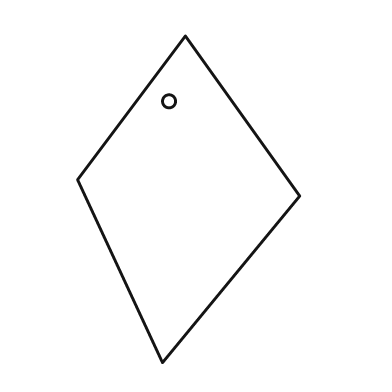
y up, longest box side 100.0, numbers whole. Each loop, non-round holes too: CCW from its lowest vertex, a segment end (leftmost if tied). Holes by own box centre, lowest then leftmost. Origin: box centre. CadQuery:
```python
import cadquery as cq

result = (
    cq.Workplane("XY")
    .moveTo(-8.0, -50.0)
    .lineTo(34.0, 1.0)
    .lineTo(-1.0, 50.0)
    .lineTo(-34.0, 6.0)
    .close()
    .moveTo(-6.0, 30.0)
    .circle(2.0)
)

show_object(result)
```